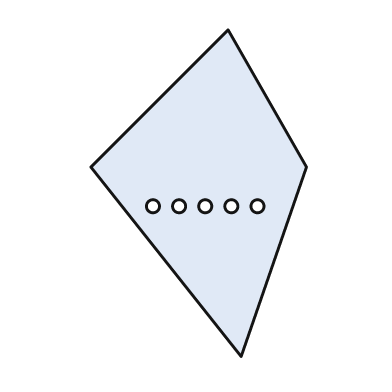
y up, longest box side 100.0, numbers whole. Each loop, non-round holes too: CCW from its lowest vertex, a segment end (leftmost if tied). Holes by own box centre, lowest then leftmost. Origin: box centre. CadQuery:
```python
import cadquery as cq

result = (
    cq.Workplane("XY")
    .moveTo(13.0, -50.0)
    .lineTo(33.0, 8.0)
    .lineTo(9.0, 50.0)
    .lineTo(-33.0, 8.0)
    .close()
    .moveTo(-14.0, -4.0)
    .circle(2.0)
    .moveTo(-6.0, -4.0)
    .circle(2.0)
    .moveTo(2.0, -4.0)
    .circle(2.0)
    .moveTo(10.0, -4.0)
    .circle(2.0)
    .moveTo(18.0, -4.0)
    .circle(2.0)
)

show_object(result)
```